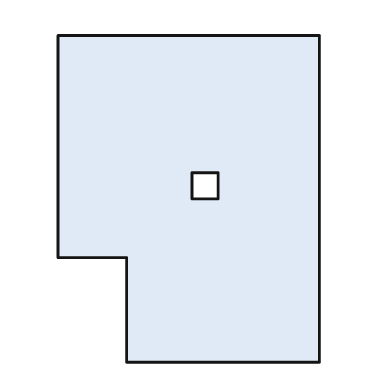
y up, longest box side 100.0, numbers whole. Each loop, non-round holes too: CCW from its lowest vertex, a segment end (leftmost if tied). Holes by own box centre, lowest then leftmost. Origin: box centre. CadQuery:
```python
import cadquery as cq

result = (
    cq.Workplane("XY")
    .moveTo(-19.0, -50.0)
    .lineTo(40.0, -50.0)
    .lineTo(40.0, 50.0)
    .lineTo(-40.0, 50.0)
    .lineTo(-40.0, -18.0)
    .lineTo(-19.0, -18.0)
    .close()
    .moveTo(1.0, 0.0)
    .lineTo(9.0, 0.0)
    .lineTo(9.0, 8.0)
    .lineTo(1.0, 8.0)
    .close()
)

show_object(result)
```